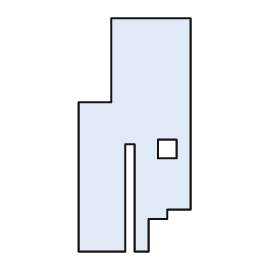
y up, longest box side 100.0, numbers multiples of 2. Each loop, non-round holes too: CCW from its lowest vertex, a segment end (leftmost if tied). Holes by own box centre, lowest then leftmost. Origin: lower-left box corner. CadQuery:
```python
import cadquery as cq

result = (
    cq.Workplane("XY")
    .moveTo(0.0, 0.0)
    .lineTo(20.0, 0.0)
    .lineTo(20.0, 46.0)
    .lineTo(24.0, 46.0)
    .lineTo(24.0, 0.0)
    .lineTo(30.0, 0.0)
    .lineTo(30.0, 14.0)
    .lineTo(38.0, 14.0)
    .lineTo(38.0, 18.0)
    .lineTo(48.0, 18.0)
    .lineTo(48.0, 100.0)
    .lineTo(14.0, 100.0)
    .lineTo(14.0, 64.0)
    .lineTo(0.0, 64.0)
    .close()
    .moveTo(34.0, 40.0)
    .lineTo(42.0, 40.0)
    .lineTo(42.0, 48.0)
    .lineTo(34.0, 48.0)
    .close()
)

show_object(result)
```